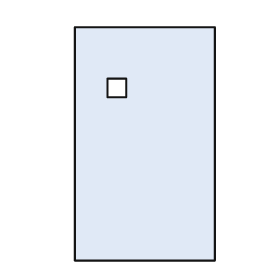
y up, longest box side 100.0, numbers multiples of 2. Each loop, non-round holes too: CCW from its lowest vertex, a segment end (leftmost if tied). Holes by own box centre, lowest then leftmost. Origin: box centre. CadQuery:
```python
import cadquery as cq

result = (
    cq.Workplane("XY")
    .moveTo(-30.0, -50.0)
    .lineTo(30.0, -50.0)
    .lineTo(30.0, 50.0)
    .lineTo(-30.0, 50.0)
    .close()
    .moveTo(-16.0, 20.0)
    .lineTo(-8.0, 20.0)
    .lineTo(-8.0, 28.0)
    .lineTo(-16.0, 28.0)
    .close()
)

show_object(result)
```